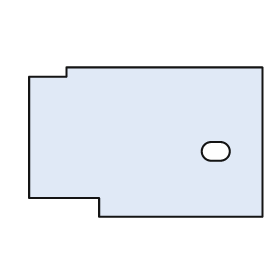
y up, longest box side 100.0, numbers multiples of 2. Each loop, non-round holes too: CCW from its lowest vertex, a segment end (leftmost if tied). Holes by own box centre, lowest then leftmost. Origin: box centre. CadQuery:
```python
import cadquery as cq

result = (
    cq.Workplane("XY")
    .moveTo(-20.0, -32.0)
    .lineTo(50.0, -32.0)
    .lineTo(50.0, 32.0)
    .lineTo(-34.0, 32.0)
    .lineTo(-34.0, 28.0)
    .lineTo(-50.0, 28.0)
    .lineTo(-50.0, -24.0)
    .lineTo(-20.0, -24.0)
    .close()
    .moveTo(28.0, -8.0)
    .lineTo(32.0, -8.0)
    .threePointArc((36.0, -4.0), (32.0, 0.0))
    .lineTo(28.0, 0.0)
    .threePointArc((24.0, -4.0), (28.0, -8.0))
    .close()
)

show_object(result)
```